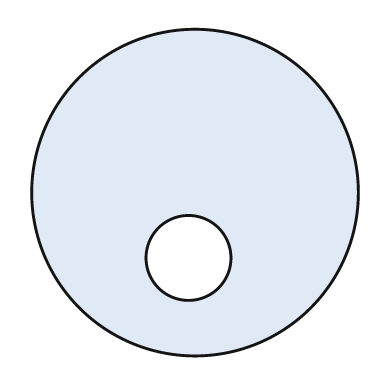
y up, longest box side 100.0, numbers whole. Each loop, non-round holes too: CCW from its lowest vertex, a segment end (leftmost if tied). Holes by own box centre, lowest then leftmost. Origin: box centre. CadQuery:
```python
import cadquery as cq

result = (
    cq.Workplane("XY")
    .moveTo(0.0, 0.0)
    .circle(50.0)
    .moveTo(-2.0, -20.0)
    .circle(13.0)
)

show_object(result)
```